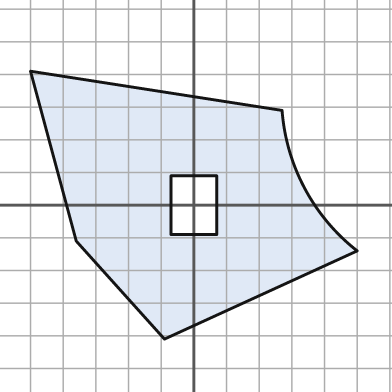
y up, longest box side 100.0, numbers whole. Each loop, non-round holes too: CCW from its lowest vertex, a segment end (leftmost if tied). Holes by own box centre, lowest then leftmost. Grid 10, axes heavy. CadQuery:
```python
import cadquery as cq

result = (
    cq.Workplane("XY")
    .moveTo(-9.0, -41.0)
    .lineTo(50.0, -14.0)
    .threePointArc((34.0, 5.0), (27.0, 29.0))
    .lineTo(-50.0, 41.0)
    .lineTo(-36.0, -11.0)
    .close()
    .moveTo(-7.0, -9.0)
    .lineTo(7.0, -9.0)
    .lineTo(7.0, 9.0)
    .lineTo(-7.0, 9.0)
    .close()
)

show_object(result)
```